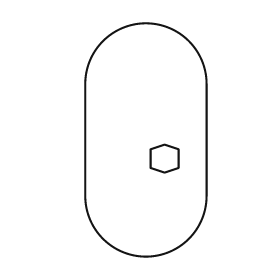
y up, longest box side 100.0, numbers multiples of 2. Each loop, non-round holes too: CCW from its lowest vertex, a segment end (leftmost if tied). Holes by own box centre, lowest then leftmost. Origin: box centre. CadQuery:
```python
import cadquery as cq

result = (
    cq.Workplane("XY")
    .moveTo(-26.0, -24.0)
    .threePointArc((0.0, -50.0), (26.0, -24.0))
    .lineTo(26.0, 24.0)
    .threePointArc((0.0, 50.0), (-26.0, 24.0))
    .close()
    .moveTo(8.0, -14.0)
    .lineTo(14.0, -12.0)
    .lineTo(14.0, -4.0)
    .lineTo(8.0, -2.0)
    .lineTo(2.0, -4.0)
    .lineTo(2.0, -12.0)
    .close()
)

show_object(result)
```